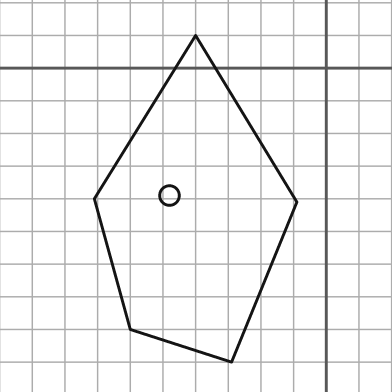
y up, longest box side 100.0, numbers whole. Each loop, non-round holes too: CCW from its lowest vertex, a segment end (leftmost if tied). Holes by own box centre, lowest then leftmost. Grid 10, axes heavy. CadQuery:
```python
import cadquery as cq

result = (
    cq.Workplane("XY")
    .moveTo(-29.0, -90.0)
    .lineTo(-9.0, -41.0)
    .lineTo(-40.0, 10.0)
    .lineTo(-71.0, -40.0)
    .lineTo(-60.0, -80.0)
    .close()
    .moveTo(-48.0, -39.0)
    .circle(3.0)
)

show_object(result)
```